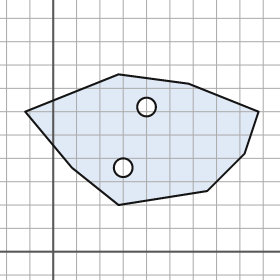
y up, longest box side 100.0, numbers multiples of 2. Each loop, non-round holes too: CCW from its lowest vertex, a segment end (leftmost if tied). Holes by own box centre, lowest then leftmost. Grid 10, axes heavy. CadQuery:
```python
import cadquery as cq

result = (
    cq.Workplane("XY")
    .moveTo(28.0, 20.0)
    .lineTo(66.0, 26.0)
    .lineTo(82.0, 42.0)
    .lineTo(88.0, 60.0)
    .lineTo(58.0, 72.0)
    .lineTo(28.0, 76.0)
    .lineTo(-12.0, 60.0)
    .lineTo(8.0, 36.0)
    .close()
    .moveTo(30.0, 36.0)
    .circle(4.0)
    .moveTo(40.0, 62.0)
    .circle(4.0)
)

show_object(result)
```